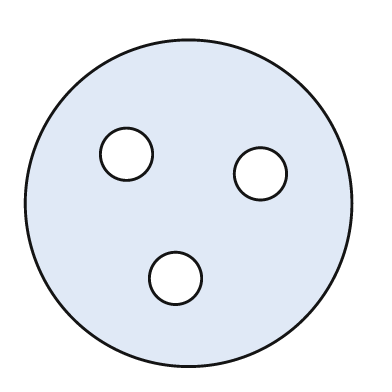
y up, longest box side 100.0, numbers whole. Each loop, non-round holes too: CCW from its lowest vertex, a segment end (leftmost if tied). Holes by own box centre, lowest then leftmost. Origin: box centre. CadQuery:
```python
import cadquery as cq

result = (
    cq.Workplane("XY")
    .moveTo(0.0, 0.0)
    .circle(50.0)
    .moveTo(-4.0, -23.0)
    .circle(8.0)
    .moveTo(22.0, 9.0)
    .circle(8.0)
    .moveTo(-19.0, 15.0)
    .circle(8.0)
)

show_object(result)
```